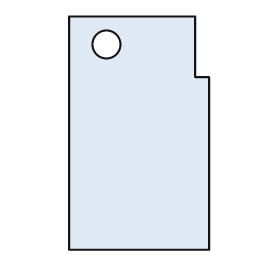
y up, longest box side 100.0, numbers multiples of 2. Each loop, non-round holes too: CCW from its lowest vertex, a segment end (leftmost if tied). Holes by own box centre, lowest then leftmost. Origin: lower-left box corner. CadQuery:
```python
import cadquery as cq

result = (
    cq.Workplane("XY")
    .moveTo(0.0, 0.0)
    .lineTo(60.0, 0.0)
    .lineTo(60.0, 74.0)
    .lineTo(54.0, 74.0)
    .lineTo(54.0, 100.0)
    .lineTo(0.0, 100.0)
    .close()
    .moveTo(16.0, 88.0)
    .circle(6.0)
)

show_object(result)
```